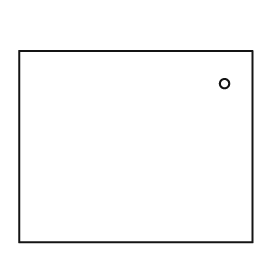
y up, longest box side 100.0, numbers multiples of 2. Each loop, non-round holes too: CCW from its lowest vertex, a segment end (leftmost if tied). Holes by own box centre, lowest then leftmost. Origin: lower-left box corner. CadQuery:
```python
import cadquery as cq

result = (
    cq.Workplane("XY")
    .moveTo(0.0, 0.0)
    .lineTo(100.0, 0.0)
    .lineTo(100.0, 82.0)
    .lineTo(0.0, 82.0)
    .close()
    .moveTo(88.0, 68.0)
    .circle(2.0)
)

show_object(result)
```